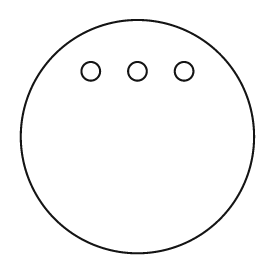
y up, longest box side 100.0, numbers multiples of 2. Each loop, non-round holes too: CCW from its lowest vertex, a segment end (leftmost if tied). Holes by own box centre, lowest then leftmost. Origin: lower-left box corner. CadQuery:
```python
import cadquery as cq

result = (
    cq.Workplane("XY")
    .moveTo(50.0, 50.0)
    .circle(50.0)
    .moveTo(30.0, 78.0)
    .circle(4.0)
    .moveTo(50.0, 78.0)
    .circle(4.0)
    .moveTo(70.0, 78.0)
    .circle(4.0)
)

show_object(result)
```